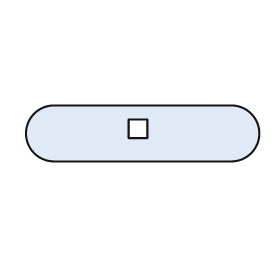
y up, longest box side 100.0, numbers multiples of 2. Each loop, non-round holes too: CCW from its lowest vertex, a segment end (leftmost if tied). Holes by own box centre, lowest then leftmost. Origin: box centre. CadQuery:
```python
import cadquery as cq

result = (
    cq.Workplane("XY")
    .moveTo(-38.0, -12.0)
    .lineTo(38.0, -12.0)
    .threePointArc((50.0, 0.0), (38.0, 12.0))
    .lineTo(-38.0, 12.0)
    .threePointArc((-50.0, 0.0), (-38.0, -12.0))
    .close()
    .moveTo(-6.0, -2.0)
    .lineTo(2.0, -2.0)
    .lineTo(2.0, 6.0)
    .lineTo(-6.0, 6.0)
    .close()
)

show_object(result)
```